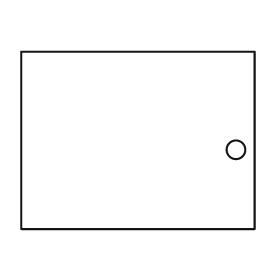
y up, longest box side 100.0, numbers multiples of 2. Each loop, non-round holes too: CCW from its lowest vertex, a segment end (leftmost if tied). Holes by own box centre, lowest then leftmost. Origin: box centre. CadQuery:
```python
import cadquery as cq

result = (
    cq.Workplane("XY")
    .moveTo(-50.0, -38.0)
    .lineTo(50.0, -38.0)
    .lineTo(50.0, 38.0)
    .lineTo(-50.0, 38.0)
    .close()
    .moveTo(42.0, -4.0)
    .circle(4.0)
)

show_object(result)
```